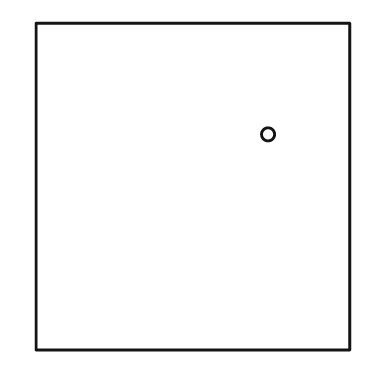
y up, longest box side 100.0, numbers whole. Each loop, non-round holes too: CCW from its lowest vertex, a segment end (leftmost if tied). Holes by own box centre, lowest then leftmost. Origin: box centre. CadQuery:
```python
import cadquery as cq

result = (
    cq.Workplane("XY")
    .moveTo(-48.0, -50.0)
    .lineTo(48.0, -50.0)
    .lineTo(48.0, 50.0)
    .lineTo(-48.0, 50.0)
    .close()
    .moveTo(23.0, 16.0)
    .circle(2.0)
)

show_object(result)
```